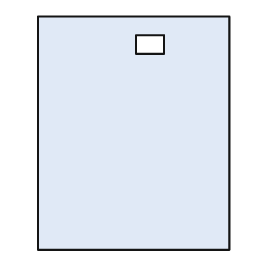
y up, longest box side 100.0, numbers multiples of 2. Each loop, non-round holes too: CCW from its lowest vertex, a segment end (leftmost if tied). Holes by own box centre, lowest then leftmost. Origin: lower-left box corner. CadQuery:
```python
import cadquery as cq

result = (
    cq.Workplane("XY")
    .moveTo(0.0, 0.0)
    .lineTo(82.0, 0.0)
    .lineTo(82.0, 100.0)
    .lineTo(0.0, 100.0)
    .close()
    .moveTo(42.0, 84.0)
    .lineTo(54.0, 84.0)
    .lineTo(54.0, 92.0)
    .lineTo(42.0, 92.0)
    .close()
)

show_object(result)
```